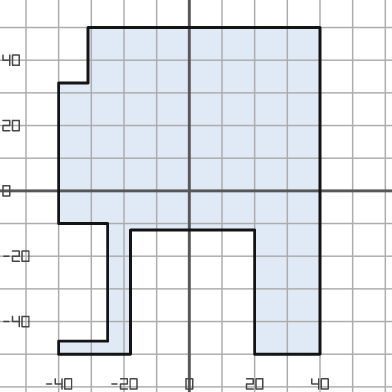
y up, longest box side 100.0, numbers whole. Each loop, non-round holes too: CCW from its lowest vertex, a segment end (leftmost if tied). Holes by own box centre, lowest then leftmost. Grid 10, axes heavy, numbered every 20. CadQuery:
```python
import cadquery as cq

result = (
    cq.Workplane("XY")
    .moveTo(-40.0, -50.0)
    .lineTo(-18.0, -50.0)
    .lineTo(-18.0, -12.0)
    .lineTo(20.0, -12.0)
    .lineTo(20.0, -50.0)
    .lineTo(40.0, -50.0)
    .lineTo(40.0, 50.0)
    .lineTo(-31.0, 50.0)
    .lineTo(-31.0, 33.0)
    .lineTo(-40.0, 33.0)
    .lineTo(-40.0, -10.0)
    .lineTo(-25.0, -10.0)
    .lineTo(-25.0, -46.0)
    .lineTo(-40.0, -46.0)
    .close()
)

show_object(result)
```